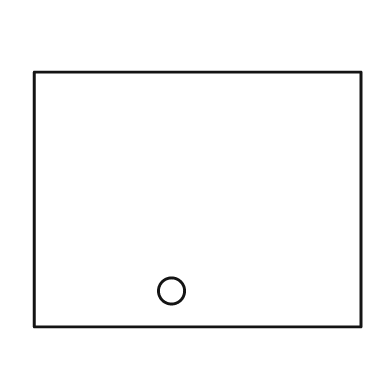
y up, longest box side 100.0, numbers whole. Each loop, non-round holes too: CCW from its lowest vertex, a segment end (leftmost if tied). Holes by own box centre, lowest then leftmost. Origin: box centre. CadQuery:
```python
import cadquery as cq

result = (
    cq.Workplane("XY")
    .moveTo(-50.0, -39.0)
    .lineTo(50.0, -39.0)
    .lineTo(50.0, 39.0)
    .lineTo(-50.0, 39.0)
    .close()
    .moveTo(-8.0, -28.0)
    .circle(4.0)
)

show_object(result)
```